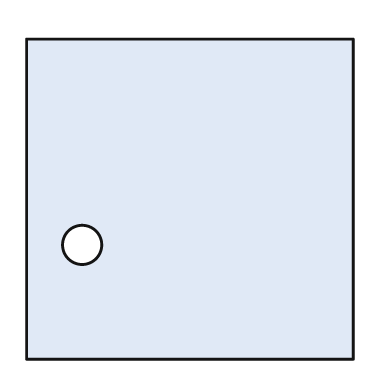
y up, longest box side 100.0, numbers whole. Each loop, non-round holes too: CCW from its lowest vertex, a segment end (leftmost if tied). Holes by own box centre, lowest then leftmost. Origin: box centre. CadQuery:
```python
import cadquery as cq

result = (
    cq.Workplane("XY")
    .moveTo(-50.0, -49.0)
    .lineTo(50.0, -49.0)
    .lineTo(50.0, 49.0)
    .lineTo(-50.0, 49.0)
    .close()
    .moveTo(-33.0, -14.0)
    .circle(6.0)
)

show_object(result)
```